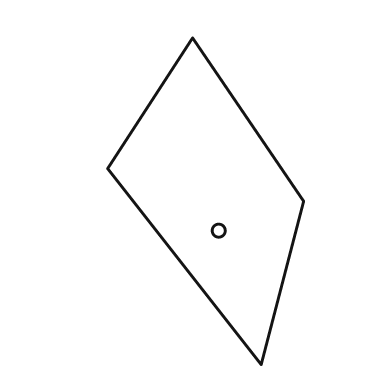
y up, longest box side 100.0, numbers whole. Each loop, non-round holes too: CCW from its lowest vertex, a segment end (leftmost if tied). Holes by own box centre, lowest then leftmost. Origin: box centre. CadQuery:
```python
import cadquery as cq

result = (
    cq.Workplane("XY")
    .moveTo(17.0, -50.0)
    .lineTo(30.0, 0.0)
    .lineTo(-4.0, 50.0)
    .lineTo(-30.0, 10.0)
    .close()
    .moveTo(4.0, -9.0)
    .circle(2.0)
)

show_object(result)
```